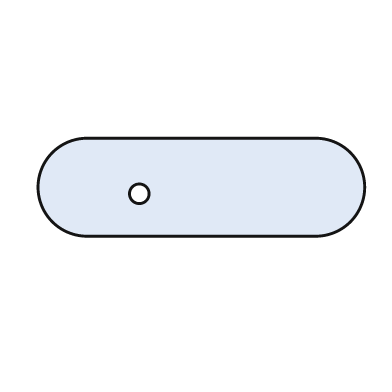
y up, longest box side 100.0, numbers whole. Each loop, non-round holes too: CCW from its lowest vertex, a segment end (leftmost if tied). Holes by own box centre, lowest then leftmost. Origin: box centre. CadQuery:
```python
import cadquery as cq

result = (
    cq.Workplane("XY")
    .moveTo(-35.0, -15.0)
    .lineTo(35.0, -15.0)
    .threePointArc((50.0, 0.0), (35.0, 15.0))
    .lineTo(-35.0, 15.0)
    .threePointArc((-50.0, 0.0), (-35.0, -15.0))
    .close()
    .moveTo(-19.0, -2.0)
    .circle(3.0)
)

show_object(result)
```